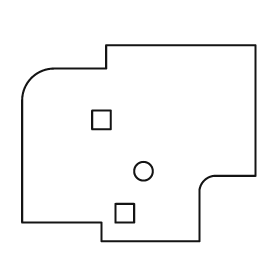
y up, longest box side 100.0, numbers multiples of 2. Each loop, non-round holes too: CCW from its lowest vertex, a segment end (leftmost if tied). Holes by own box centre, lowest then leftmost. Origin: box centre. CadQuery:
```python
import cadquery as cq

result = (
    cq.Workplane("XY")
    .moveTo(-16.0, -42.0)
    .lineTo(26.0, -42.0)
    .lineTo(26.0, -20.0)
    .threePointArc((28.0, -16.0), (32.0, -14.0))
    .lineTo(50.0, -14.0)
    .lineTo(50.0, 42.0)
    .lineTo(-14.0, 42.0)
    .lineTo(-14.0, 32.0)
    .lineTo(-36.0, 32.0)
    .threePointArc((-46.0, 28.0), (-50.0, 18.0))
    .lineTo(-50.0, -34.0)
    .lineTo(-16.0, -34.0)
    .close()
    .moveTo(-10.0, -34.0)
    .lineTo(-2.0, -34.0)
    .lineTo(-2.0, -26.0)
    .lineTo(-10.0, -26.0)
    .close()
    .moveTo(2.0, -12.0)
    .circle(4.0)
    .moveTo(-20.0, 6.0)
    .lineTo(-12.0, 6.0)
    .lineTo(-12.0, 14.0)
    .lineTo(-20.0, 14.0)
    .close()
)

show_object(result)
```